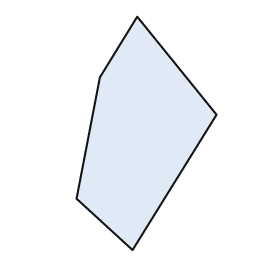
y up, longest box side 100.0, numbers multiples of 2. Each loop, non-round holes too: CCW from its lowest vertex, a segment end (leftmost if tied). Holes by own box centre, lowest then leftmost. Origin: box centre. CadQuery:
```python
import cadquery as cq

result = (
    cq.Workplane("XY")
    .moveTo(-6.0, -50.0)
    .lineTo(30.0, 8.0)
    .lineTo(-4.0, 50.0)
    .lineTo(-20.0, 24.0)
    .lineTo(-30.0, -28.0)
    .close()
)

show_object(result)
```